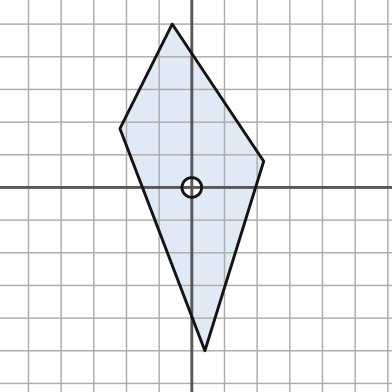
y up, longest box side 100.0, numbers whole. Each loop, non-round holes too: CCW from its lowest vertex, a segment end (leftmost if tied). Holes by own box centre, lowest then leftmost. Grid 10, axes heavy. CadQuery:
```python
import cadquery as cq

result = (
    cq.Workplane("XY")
    .moveTo(4.0, -50.0)
    .lineTo(22.0, 8.0)
    .lineTo(-6.0, 50.0)
    .lineTo(-22.0, 18.0)
    .close()
    .moveTo(0.0, 0.0)
    .circle(3.0)
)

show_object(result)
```